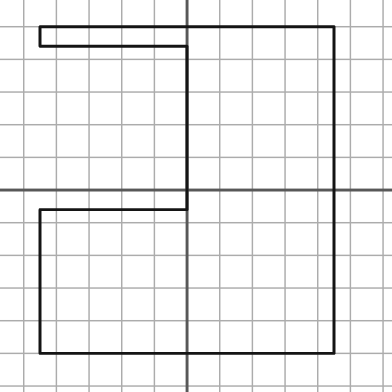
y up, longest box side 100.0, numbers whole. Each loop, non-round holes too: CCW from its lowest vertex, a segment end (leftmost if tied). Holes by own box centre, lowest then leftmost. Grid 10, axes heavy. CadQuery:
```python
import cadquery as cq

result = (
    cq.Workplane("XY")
    .moveTo(-45.0, -50.0)
    .lineTo(45.0, -50.0)
    .lineTo(45.0, 50.0)
    .lineTo(-45.0, 50.0)
    .lineTo(-45.0, 44.0)
    .lineTo(0.0, 44.0)
    .lineTo(0.0, -6.0)
    .lineTo(-45.0, -6.0)
    .close()
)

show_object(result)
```